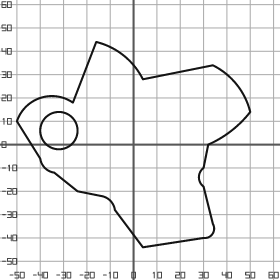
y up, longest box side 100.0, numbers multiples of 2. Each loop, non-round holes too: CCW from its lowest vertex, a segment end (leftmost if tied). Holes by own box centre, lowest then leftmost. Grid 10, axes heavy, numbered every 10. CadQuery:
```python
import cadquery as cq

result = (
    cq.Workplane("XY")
    .moveTo(4.0, -44.0)
    .lineTo(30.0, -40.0)
    .threePointArc((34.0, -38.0), (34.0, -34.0))
    .lineTo(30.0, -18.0)
    .threePointArc((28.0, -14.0), (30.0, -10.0))
    .lineTo(32.0, 0.0)
    .threePointArc((42.0, 6.0), (50.0, 14.0))
    .threePointArc((44.0, 26.0), (34.0, 34.0))
    .lineTo(4.0, 28.0)
    .threePointArc((-4.0, 38.0), (-16.0, 44.0))
    .lineTo(-26.0, 18.0)
    .threePointArc((-40.0, 20.0), (-50.0, 10.0))
    .lineTo(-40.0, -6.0)
    .threePointArc((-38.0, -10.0), (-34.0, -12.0))
    .lineTo(-24.0, -20.0)
    .lineTo(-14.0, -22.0)
    .threePointArc((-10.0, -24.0), (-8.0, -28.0))
    .close()
    .moveTo(-32.0, 6.0)
    .circle(8.0)
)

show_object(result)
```